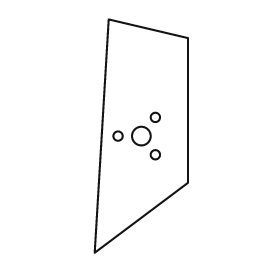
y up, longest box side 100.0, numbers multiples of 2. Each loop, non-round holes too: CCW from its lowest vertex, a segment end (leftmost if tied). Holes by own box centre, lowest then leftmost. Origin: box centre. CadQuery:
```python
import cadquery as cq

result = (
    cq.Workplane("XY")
    .moveTo(-20.0, -50.0)
    .lineTo(20.0, -20.0)
    .lineTo(20.0, 42.0)
    .lineTo(-14.0, 50.0)
    .close()
    .moveTo(6.0, -8.0)
    .circle(2.0)
    .moveTo(-10.0, 0.0)
    .circle(2.0)
    .moveTo(0.0, 0.0)
    .circle(4.0)
    .moveTo(6.0, 8.0)
    .circle(2.0)
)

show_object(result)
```